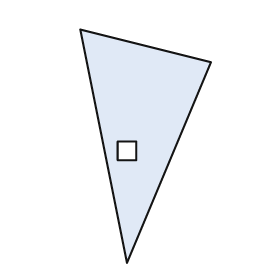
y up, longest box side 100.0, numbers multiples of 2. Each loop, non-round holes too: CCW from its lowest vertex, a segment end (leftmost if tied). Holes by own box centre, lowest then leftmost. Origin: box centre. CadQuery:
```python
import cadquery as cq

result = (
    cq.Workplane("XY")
    .moveTo(-8.0, -50.0)
    .lineTo(28.0, 36.0)
    .lineTo(-28.0, 50.0)
    .close()
    .moveTo(-12.0, -6.0)
    .lineTo(-4.0, -6.0)
    .lineTo(-4.0, 2.0)
    .lineTo(-12.0, 2.0)
    .close()
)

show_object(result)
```